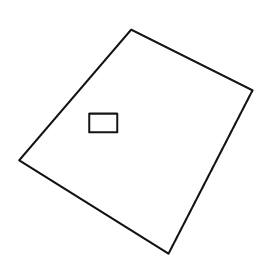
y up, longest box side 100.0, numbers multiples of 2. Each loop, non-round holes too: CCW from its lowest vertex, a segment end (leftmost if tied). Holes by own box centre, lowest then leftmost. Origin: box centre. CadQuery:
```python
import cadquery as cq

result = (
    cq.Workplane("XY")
    .moveTo(14.0, -48.0)
    .lineTo(50.0, 22.0)
    .lineTo(-2.0, 48.0)
    .lineTo(-50.0, -8.0)
    .close()
    .moveTo(-20.0, 4.0)
    .lineTo(-8.0, 4.0)
    .lineTo(-8.0, 12.0)
    .lineTo(-20.0, 12.0)
    .close()
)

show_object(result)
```